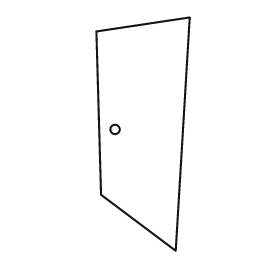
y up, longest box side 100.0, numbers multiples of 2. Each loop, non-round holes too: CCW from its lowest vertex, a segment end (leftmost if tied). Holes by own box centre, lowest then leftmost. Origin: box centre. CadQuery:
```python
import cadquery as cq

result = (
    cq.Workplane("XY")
    .moveTo(14.0, -50.0)
    .lineTo(20.0, 50.0)
    .lineTo(-20.0, 44.0)
    .lineTo(-18.0, -26.0)
    .close()
    .moveTo(-12.0, 2.0)
    .circle(2.0)
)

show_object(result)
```